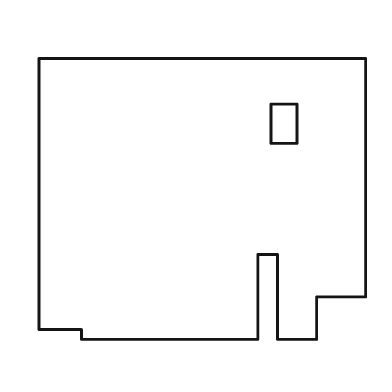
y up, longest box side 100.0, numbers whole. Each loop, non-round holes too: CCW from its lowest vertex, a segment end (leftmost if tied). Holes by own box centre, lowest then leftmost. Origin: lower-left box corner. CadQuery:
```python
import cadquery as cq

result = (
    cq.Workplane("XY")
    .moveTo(13.0, 0.0)
    .lineTo(67.0, 0.0)
    .lineTo(67.0, 26.0)
    .lineTo(73.0, 26.0)
    .lineTo(73.0, 0.0)
    .lineTo(85.0, 0.0)
    .lineTo(85.0, 13.0)
    .lineTo(100.0, 13.0)
    .lineTo(100.0, 86.0)
    .lineTo(0.0, 86.0)
    .lineTo(0.0, 3.0)
    .lineTo(13.0, 3.0)
    .close()
    .moveTo(71.0, 60.0)
    .lineTo(79.0, 60.0)
    .lineTo(79.0, 72.0)
    .lineTo(71.0, 72.0)
    .close()
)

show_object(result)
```